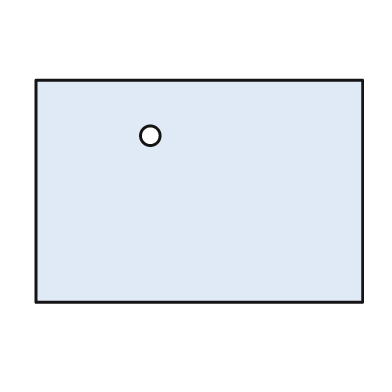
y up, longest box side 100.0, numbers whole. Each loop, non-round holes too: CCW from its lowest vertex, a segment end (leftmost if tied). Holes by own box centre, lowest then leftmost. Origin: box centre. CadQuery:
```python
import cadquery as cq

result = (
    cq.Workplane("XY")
    .moveTo(-50.0, -34.0)
    .lineTo(50.0, -34.0)
    .lineTo(50.0, 34.0)
    .lineTo(-50.0, 34.0)
    .close()
    .moveTo(-15.0, 17.0)
    .circle(3.0)
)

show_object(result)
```